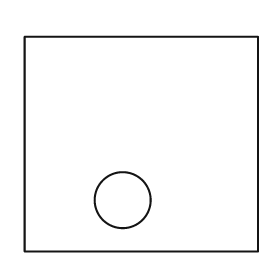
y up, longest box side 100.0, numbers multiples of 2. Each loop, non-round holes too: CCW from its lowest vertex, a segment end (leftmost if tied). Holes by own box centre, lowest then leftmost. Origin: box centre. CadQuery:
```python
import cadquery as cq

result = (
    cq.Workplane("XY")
    .moveTo(-50.0, -46.0)
    .lineTo(50.0, -46.0)
    .lineTo(50.0, 46.0)
    .lineTo(-50.0, 46.0)
    .close()
    .moveTo(-8.0, -24.0)
    .circle(12.0)
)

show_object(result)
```